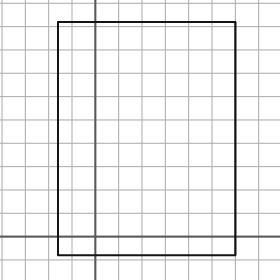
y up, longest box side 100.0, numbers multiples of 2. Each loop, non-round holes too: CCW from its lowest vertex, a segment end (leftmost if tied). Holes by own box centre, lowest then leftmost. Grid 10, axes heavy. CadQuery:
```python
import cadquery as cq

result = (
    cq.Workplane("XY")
    .moveTo(-16.0, -8.0)
    .lineTo(60.0, -8.0)
    .lineTo(60.0, 92.0)
    .lineTo(-16.0, 92.0)
    .close()
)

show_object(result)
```